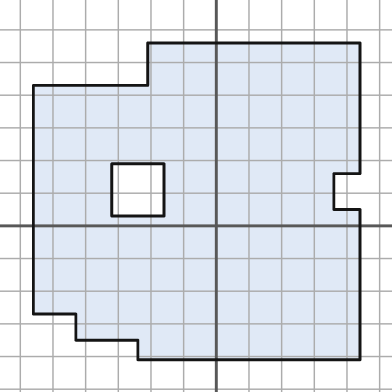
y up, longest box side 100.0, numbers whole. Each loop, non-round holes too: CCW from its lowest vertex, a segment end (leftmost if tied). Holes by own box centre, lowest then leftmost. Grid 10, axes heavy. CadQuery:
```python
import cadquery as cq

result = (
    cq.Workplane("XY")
    .moveTo(-24.0, -41.0)
    .lineTo(44.0, -41.0)
    .lineTo(44.0, 5.0)
    .lineTo(36.0, 5.0)
    .lineTo(36.0, 16.0)
    .lineTo(44.0, 16.0)
    .lineTo(44.0, 56.0)
    .lineTo(-21.0, 56.0)
    .lineTo(-21.0, 43.0)
    .lineTo(-56.0, 43.0)
    .lineTo(-56.0, -27.0)
    .lineTo(-43.0, -27.0)
    .lineTo(-43.0, -35.0)
    .lineTo(-24.0, -35.0)
    .close()
    .moveTo(-32.0, 3.0)
    .lineTo(-16.0, 3.0)
    .lineTo(-16.0, 19.0)
    .lineTo(-32.0, 19.0)
    .close()
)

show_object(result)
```